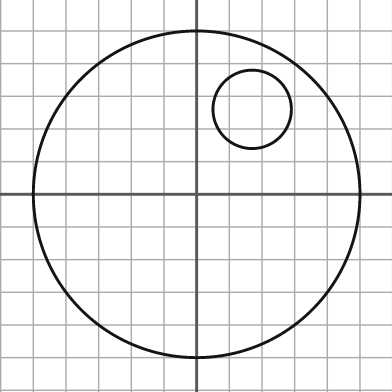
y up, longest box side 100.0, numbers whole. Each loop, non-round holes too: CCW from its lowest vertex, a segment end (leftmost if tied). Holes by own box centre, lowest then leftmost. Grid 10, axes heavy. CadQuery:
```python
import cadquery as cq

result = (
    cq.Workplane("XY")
    .moveTo(0.0, 0.0)
    .circle(50.0)
    .moveTo(17.0, 26.0)
    .circle(12.0)
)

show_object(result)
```